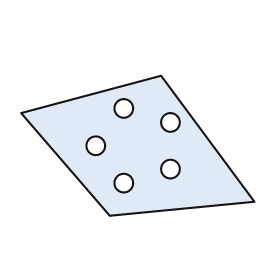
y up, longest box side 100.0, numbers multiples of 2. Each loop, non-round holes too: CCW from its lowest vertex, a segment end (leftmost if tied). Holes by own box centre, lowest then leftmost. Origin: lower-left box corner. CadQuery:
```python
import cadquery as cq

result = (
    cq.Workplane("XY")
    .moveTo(38.0, 0.0)
    .lineTo(100.0, 6.0)
    .lineTo(60.0, 60.0)
    .lineTo(0.0, 44.0)
    .close()
    .moveTo(44.0, 14.0)
    .circle(4.0)
    .moveTo(64.0, 20.0)
    .circle(4.0)
    .moveTo(32.0, 30.0)
    .circle(4.0)
    .moveTo(64.0, 40.0)
    .circle(4.0)
    .moveTo(44.0, 46.0)
    .circle(4.0)
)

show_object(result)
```